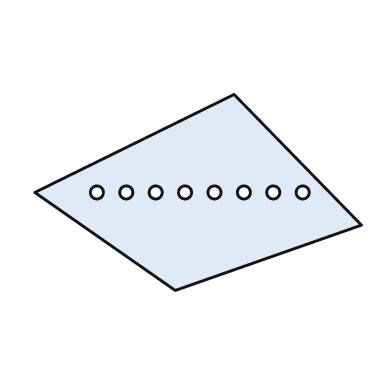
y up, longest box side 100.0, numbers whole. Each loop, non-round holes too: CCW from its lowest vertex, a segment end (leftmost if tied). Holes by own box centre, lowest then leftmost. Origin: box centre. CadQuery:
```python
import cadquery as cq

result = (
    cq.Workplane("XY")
    .moveTo(-7.0, -30.0)
    .lineTo(50.0, -10.0)
    .lineTo(11.0, 30.0)
    .lineTo(-50.0, 0.0)
    .close()
    .moveTo(-31.0, 0.0)
    .circle(2.0)
    .moveTo(-22.0, 0.0)
    .circle(2.0)
    .moveTo(-13.0, 0.0)
    .circle(2.0)
    .moveTo(-4.0, 0.0)
    .circle(2.0)
    .moveTo(5.0, 0.0)
    .circle(2.0)
    .moveTo(14.0, 0.0)
    .circle(2.0)
    .moveTo(23.0, 0.0)
    .circle(2.0)
    .moveTo(32.0, 0.0)
    .circle(2.0)
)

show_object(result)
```